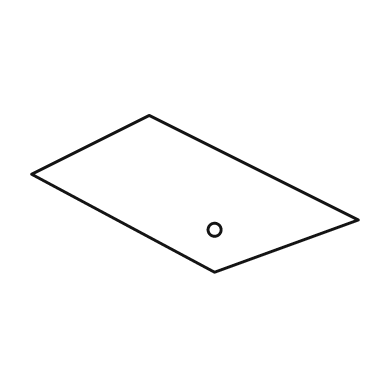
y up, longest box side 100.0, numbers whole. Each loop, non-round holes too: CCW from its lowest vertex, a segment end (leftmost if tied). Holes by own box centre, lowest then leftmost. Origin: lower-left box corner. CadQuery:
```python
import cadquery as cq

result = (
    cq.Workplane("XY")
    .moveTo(56.0, 0.0)
    .lineTo(100.0, 16.0)
    .lineTo(36.0, 48.0)
    .lineTo(0.0, 30.0)
    .close()
    .moveTo(56.0, 13.0)
    .circle(2.0)
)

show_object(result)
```